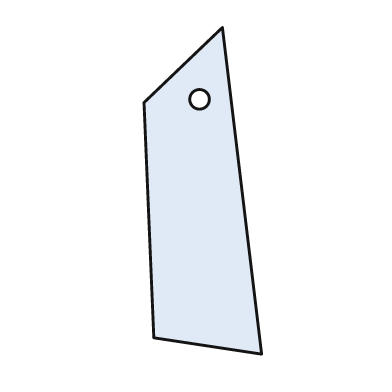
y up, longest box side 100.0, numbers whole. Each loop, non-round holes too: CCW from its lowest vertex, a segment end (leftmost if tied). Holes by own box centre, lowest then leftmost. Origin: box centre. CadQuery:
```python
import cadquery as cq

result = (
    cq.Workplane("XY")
    .moveTo(18.0, -50.0)
    .lineTo(6.0, 50.0)
    .lineTo(-18.0, 27.0)
    .lineTo(-15.0, -45.0)
    .close()
    .moveTo(-1.0, 28.0)
    .circle(3.0)
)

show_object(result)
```